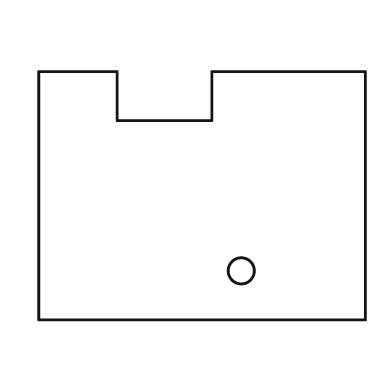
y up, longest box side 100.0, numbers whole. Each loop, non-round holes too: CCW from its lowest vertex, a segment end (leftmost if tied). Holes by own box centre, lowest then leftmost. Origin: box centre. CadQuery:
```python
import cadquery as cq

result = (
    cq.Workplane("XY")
    .moveTo(-50.0, -38.0)
    .lineTo(50.0, -38.0)
    .lineTo(50.0, 38.0)
    .lineTo(3.0, 38.0)
    .lineTo(3.0, 23.0)
    .lineTo(-26.0, 23.0)
    .lineTo(-26.0, 38.0)
    .lineTo(-50.0, 38.0)
    .close()
    .moveTo(12.0, -23.0)
    .circle(4.0)
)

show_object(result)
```